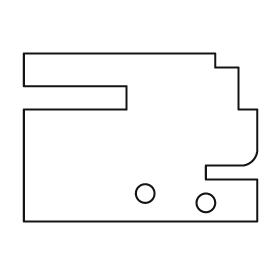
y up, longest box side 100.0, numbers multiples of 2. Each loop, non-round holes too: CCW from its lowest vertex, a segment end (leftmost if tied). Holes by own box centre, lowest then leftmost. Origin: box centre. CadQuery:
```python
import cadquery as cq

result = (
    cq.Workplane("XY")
    .moveTo(-50.0, -36.0)
    .lineTo(50.0, -36.0)
    .lineTo(50.0, -18.0)
    .lineTo(28.0, -18.0)
    .lineTo(28.0, -12.0)
    .lineTo(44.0, -12.0)
    .threePointArc((48.0, -10.0), (50.0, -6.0))
    .lineTo(50.0, 12.0)
    .lineTo(42.0, 12.0)
    .lineTo(42.0, 30.0)
    .lineTo(32.0, 30.0)
    .lineTo(32.0, 36.0)
    .lineTo(-50.0, 36.0)
    .lineTo(-50.0, 22.0)
    .lineTo(-6.0, 22.0)
    .lineTo(-6.0, 12.0)
    .lineTo(-50.0, 12.0)
    .close()
    .moveTo(28.0, -28.0)
    .circle(4.0)
    .moveTo(2.0, -24.0)
    .circle(4.0)
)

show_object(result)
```